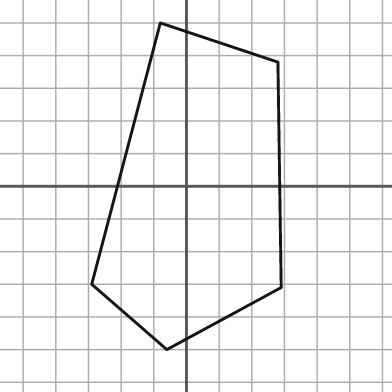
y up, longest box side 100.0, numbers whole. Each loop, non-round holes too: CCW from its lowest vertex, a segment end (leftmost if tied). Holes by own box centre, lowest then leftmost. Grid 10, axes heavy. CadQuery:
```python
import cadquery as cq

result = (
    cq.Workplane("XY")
    .moveTo(-6.0, -50.0)
    .lineTo(29.0, -31.0)
    .lineTo(28.0, 38.0)
    .lineTo(-8.0, 50.0)
    .lineTo(-29.0, -30.0)
    .close()
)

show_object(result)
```